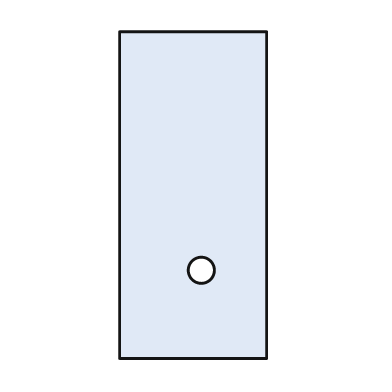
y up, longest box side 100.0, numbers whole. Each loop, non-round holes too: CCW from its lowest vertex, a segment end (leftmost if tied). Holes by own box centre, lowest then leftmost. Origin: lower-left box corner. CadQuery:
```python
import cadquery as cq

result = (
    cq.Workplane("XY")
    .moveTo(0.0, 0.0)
    .lineTo(45.0, 0.0)
    .lineTo(45.0, 100.0)
    .lineTo(0.0, 100.0)
    .close()
    .moveTo(25.0, 27.0)
    .circle(4.0)
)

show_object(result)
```